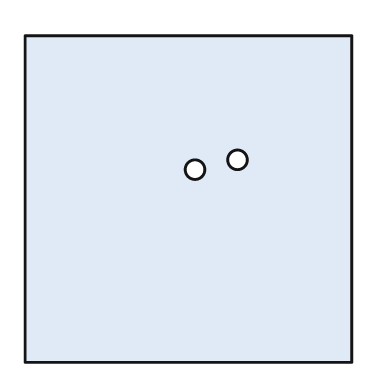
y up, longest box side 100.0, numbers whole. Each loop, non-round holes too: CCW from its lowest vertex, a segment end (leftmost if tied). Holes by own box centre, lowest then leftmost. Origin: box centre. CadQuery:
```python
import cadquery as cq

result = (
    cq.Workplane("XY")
    .moveTo(-50.0, -50.0)
    .lineTo(50.0, -50.0)
    .lineTo(50.0, 50.0)
    .lineTo(-50.0, 50.0)
    .close()
    .moveTo(2.0, 9.0)
    .circle(3.0)
    .moveTo(15.0, 12.0)
    .circle(3.0)
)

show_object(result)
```